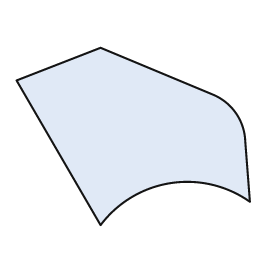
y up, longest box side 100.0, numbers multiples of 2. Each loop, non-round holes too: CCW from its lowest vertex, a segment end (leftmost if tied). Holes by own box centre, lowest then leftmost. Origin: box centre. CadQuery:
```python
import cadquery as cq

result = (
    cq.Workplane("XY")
    .moveTo(-14.0, -38.0)
    .threePointArc((16.0, -20.0), (50.0, -28.0))
    .lineTo(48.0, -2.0)
    .threePointArc((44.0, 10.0), (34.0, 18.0))
    .lineTo(-14.0, 38.0)
    .lineTo(-50.0, 24.0)
    .close()
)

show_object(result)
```